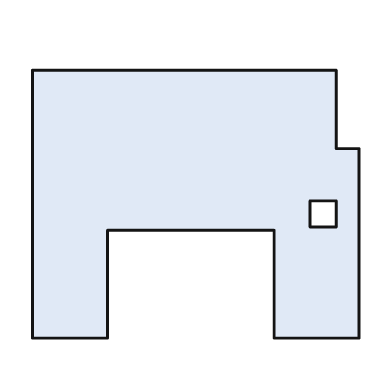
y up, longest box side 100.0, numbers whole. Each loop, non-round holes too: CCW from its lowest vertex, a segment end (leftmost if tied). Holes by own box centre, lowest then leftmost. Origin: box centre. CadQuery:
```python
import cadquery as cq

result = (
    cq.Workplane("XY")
    .moveTo(-50.0, -41.0)
    .lineTo(-27.0, -41.0)
    .lineTo(-27.0, -8.0)
    .lineTo(24.0, -8.0)
    .lineTo(24.0, -41.0)
    .lineTo(50.0, -41.0)
    .lineTo(50.0, 17.0)
    .lineTo(43.0, 17.0)
    .lineTo(43.0, 41.0)
    .lineTo(-50.0, 41.0)
    .close()
    .moveTo(35.0, -7.0)
    .lineTo(43.0, -7.0)
    .lineTo(43.0, 1.0)
    .lineTo(35.0, 1.0)
    .close()
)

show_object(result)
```